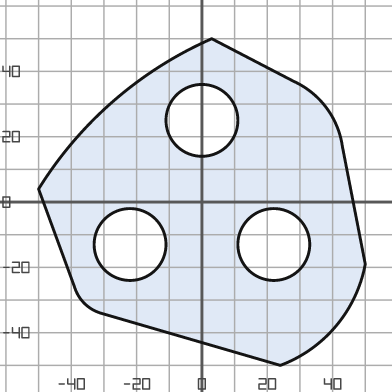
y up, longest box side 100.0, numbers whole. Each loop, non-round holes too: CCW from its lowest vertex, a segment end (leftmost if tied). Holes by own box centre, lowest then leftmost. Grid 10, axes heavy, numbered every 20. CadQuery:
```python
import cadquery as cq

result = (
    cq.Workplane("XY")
    .moveTo(24.0, -50.0)
    .threePointArc((41.0, -38.0), (50.0, -19.0))
    .lineTo(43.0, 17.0)
    .threePointArc((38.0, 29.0), (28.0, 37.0))
    .lineTo(3.0, 50.0)
    .threePointArc((-27.0, 31.0), (-50.0, 4.0))
    .lineTo(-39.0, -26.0)
    .threePointArc((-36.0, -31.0), (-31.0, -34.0))
    .close()
    .moveTo(-22.0, -13.0)
    .circle(11.0)
    .moveTo(22.0, -13.0)
    .circle(11.0)
    .moveTo(0.0, 25.0)
    .circle(11.0)
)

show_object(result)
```